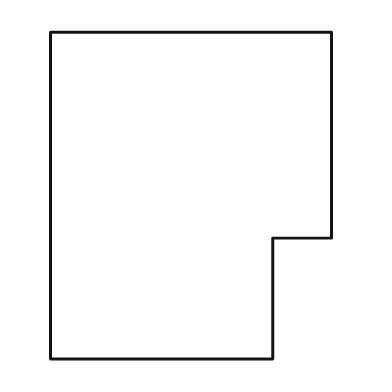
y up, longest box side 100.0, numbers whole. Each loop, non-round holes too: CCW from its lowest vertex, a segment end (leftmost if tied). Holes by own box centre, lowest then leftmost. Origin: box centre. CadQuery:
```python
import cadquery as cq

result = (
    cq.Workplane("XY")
    .moveTo(-43.0, -50.0)
    .lineTo(25.0, -50.0)
    .lineTo(25.0, -13.0)
    .lineTo(43.0, -13.0)
    .lineTo(43.0, 50.0)
    .lineTo(-43.0, 50.0)
    .close()
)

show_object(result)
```